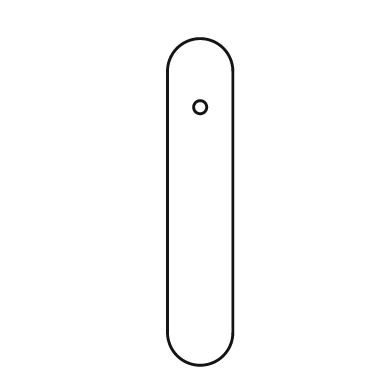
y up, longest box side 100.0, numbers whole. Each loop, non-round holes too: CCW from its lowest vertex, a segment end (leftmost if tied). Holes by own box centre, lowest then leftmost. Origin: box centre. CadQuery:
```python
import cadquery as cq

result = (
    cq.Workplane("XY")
    .moveTo(-10.0, -40.0)
    .threePointArc((0.0, -50.0), (10.0, -40.0))
    .lineTo(10.0, 40.0)
    .threePointArc((0.0, 50.0), (-10.0, 40.0))
    .close()
    .moveTo(0.0, 29.0)
    .circle(2.0)
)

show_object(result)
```